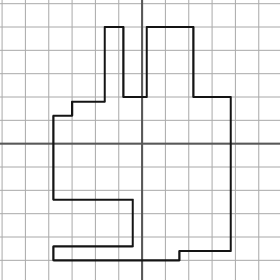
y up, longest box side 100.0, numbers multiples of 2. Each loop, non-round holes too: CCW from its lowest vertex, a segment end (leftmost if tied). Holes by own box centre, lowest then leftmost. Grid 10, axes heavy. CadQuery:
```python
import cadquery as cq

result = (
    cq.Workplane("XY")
    .moveTo(-38.0, -50.0)
    .lineTo(16.0, -50.0)
    .lineTo(16.0, -46.0)
    .lineTo(38.0, -46.0)
    .lineTo(38.0, 20.0)
    .lineTo(22.0, 20.0)
    .lineTo(22.0, 50.0)
    .lineTo(2.0, 50.0)
    .lineTo(2.0, 20.0)
    .lineTo(-8.0, 20.0)
    .lineTo(-8.0, 50.0)
    .lineTo(-16.0, 50.0)
    .lineTo(-16.0, 18.0)
    .lineTo(-30.0, 18.0)
    .lineTo(-30.0, 12.0)
    .lineTo(-38.0, 12.0)
    .lineTo(-38.0, -24.0)
    .lineTo(-4.0, -24.0)
    .lineTo(-4.0, -44.0)
    .lineTo(-38.0, -44.0)
    .close()
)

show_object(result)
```